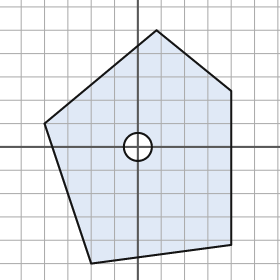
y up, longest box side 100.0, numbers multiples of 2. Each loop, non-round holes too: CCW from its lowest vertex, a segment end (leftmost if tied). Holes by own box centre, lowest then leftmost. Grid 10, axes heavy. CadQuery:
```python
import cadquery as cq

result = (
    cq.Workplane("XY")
    .moveTo(-20.0, -50.0)
    .lineTo(40.0, -42.0)
    .lineTo(40.0, 24.0)
    .lineTo(8.0, 50.0)
    .lineTo(-40.0, 10.0)
    .close()
    .moveTo(0.0, 0.0)
    .circle(6.0)
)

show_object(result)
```